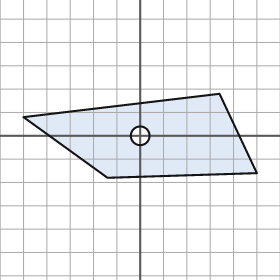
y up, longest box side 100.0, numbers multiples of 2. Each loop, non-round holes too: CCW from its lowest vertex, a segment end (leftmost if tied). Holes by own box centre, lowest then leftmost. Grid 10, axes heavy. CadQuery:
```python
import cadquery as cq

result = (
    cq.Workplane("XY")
    .moveTo(-14.0, -18.0)
    .lineTo(50.0, -16.0)
    .lineTo(34.0, 18.0)
    .lineTo(-50.0, 8.0)
    .close()
    .moveTo(0.0, 0.0)
    .circle(4.0)
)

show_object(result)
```